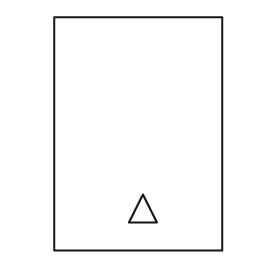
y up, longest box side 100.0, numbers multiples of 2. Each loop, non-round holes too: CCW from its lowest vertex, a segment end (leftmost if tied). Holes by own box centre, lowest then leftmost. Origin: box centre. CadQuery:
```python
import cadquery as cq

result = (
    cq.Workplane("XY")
    .moveTo(-36.0, -50.0)
    .lineTo(36.0, -50.0)
    .lineTo(36.0, 50.0)
    .lineTo(-36.0, 50.0)
    .close()
    .moveTo(-4.0, -38.0)
    .lineTo(8.0, -38.0)
    .lineTo(2.0, -26.0)
    .close()
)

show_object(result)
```